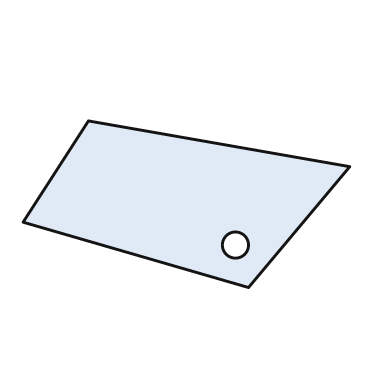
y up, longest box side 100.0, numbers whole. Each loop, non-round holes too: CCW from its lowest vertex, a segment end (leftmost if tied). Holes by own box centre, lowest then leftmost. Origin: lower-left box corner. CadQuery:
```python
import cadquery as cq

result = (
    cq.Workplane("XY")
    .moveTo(69.0, 0.0)
    .lineTo(100.0, 37.0)
    .lineTo(20.0, 51.0)
    .lineTo(0.0, 20.0)
    .close()
    .moveTo(65.0, 13.0)
    .circle(4.0)
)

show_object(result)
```